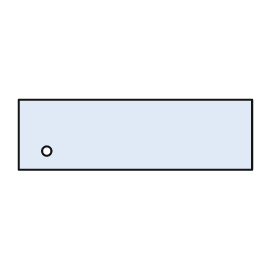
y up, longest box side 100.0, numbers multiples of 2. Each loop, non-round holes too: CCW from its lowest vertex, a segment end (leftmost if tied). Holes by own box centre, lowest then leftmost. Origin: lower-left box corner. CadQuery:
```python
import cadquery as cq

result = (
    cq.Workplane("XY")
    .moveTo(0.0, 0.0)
    .lineTo(100.0, 0.0)
    .lineTo(100.0, 30.0)
    .lineTo(0.0, 30.0)
    .close()
    .moveTo(12.0, 8.0)
    .circle(2.0)
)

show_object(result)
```